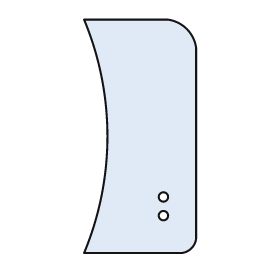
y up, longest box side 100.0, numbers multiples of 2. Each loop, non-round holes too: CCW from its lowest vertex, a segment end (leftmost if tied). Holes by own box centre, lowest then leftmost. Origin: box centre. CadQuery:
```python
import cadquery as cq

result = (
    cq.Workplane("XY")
    .moveTo(-24.0, -50.0)
    .lineTo(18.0, -50.0)
    .threePointArc((22.0, -48.0), (24.0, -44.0))
    .lineTo(24.0, 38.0)
    .threePointArc((20.0, 46.0), (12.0, 50.0))
    .lineTo(-24.0, 50.0)
    .threePointArc((-14.0, 0.0), (-24.0, -50.0))
    .close()
    .moveTo(10.0, -34.0)
    .circle(2.0)
    .moveTo(10.0, -26.0)
    .circle(2.0)
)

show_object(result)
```